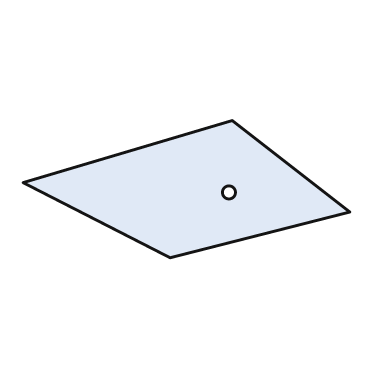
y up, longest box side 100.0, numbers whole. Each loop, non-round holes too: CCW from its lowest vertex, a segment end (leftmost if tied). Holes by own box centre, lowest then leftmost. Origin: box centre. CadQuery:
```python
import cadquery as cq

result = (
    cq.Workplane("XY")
    .moveTo(-5.0, -21.0)
    .lineTo(50.0, -7.0)
    .lineTo(14.0, 21.0)
    .lineTo(-50.0, 2.0)
    .close()
    .moveTo(13.0, -1.0)
    .circle(2.0)
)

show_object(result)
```